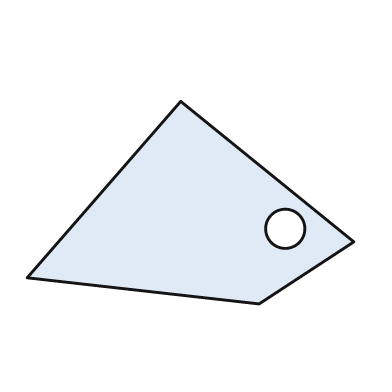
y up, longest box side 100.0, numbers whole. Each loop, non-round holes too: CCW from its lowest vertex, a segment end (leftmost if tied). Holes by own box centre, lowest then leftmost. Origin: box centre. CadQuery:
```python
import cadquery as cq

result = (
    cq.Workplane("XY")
    .moveTo(21.0, -31.0)
    .lineTo(50.0, -12.0)
    .lineTo(-3.0, 31.0)
    .lineTo(-50.0, -23.0)
    .close()
    .moveTo(29.0, -8.0)
    .circle(6.0)
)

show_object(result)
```